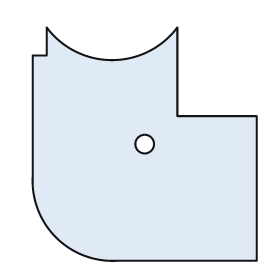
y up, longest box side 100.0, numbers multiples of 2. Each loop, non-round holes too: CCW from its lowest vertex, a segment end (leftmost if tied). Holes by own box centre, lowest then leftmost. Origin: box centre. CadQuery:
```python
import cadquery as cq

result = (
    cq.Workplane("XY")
    .moveTo(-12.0, -50.0)
    .lineTo(48.0, -50.0)
    .lineTo(48.0, 12.0)
    .lineTo(14.0, 12.0)
    .lineTo(14.0, 50.0)
    .threePointArc((-14.0, 36.0), (-42.0, 50.0))
    .lineTo(-42.0, 38.0)
    .lineTo(-48.0, 38.0)
    .lineTo(-48.0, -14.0)
    .threePointArc((-38.0, -40.0), (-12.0, -50.0))
    .close()
    .moveTo(0.0, 0.0)
    .circle(4.0)
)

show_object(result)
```